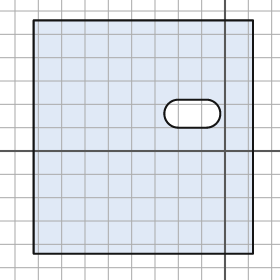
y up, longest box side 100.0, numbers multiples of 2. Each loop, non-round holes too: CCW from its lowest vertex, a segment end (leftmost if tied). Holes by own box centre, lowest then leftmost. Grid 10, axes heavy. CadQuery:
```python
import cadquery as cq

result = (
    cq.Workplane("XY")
    .moveTo(-82.0, -44.0)
    .lineTo(12.0, -44.0)
    .lineTo(12.0, 56.0)
    .lineTo(-82.0, 56.0)
    .close()
    .moveTo(-20.0, 10.0)
    .lineTo(-8.0, 10.0)
    .threePointArc((-2.0, 16.0), (-8.0, 22.0))
    .lineTo(-20.0, 22.0)
    .threePointArc((-26.0, 16.0), (-20.0, 10.0))
    .close()
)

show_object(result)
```